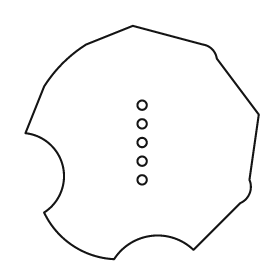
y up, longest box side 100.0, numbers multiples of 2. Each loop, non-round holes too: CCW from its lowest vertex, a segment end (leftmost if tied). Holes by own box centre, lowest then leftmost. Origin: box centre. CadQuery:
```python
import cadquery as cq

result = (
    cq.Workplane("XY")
    .moveTo(-12.0, -50.0)
    .threePointArc((4.0, -40.0), (22.0, -46.0))
    .lineTo(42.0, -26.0)
    .threePointArc((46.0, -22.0), (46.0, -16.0))
    .lineTo(50.0, 12.0)
    .lineTo(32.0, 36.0)
    .threePointArc((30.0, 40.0), (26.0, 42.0))
    .lineTo(-4.0, 50.0)
    .lineTo(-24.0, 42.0)
    .threePointArc((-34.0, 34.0), (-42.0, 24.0))
    .lineTo(-50.0, 4.0)
    .threePointArc((-34.0, -10.0), (-42.0, -30.0))
    .threePointArc((-30.0, -44.0), (-12.0, -50.0))
    .close()
    .moveTo(0.0, -16.0)
    .circle(2.0)
    .moveTo(0.0, -8.0)
    .circle(2.0)
    .moveTo(0.0, 0.0)
    .circle(2.0)
    .moveTo(0.0, 8.0)
    .circle(2.0)
    .moveTo(0.0, 16.0)
    .circle(2.0)
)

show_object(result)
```